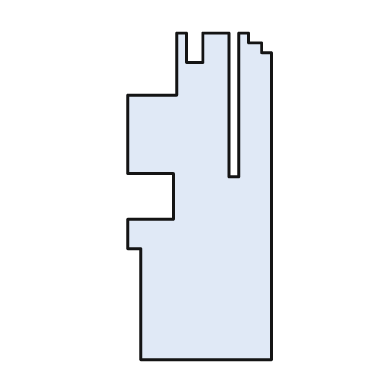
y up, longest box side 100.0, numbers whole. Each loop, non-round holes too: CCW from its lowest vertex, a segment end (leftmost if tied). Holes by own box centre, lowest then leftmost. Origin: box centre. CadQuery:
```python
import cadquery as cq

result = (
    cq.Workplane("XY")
    .moveTo(-18.0, -50.0)
    .lineTo(22.0, -50.0)
    .lineTo(22.0, 44.0)
    .lineTo(19.0, 44.0)
    .lineTo(19.0, 47.0)
    .lineTo(15.0, 47.0)
    .lineTo(15.0, 50.0)
    .lineTo(12.0, 50.0)
    .lineTo(12.0, 6.0)
    .lineTo(9.0, 6.0)
    .lineTo(9.0, 50.0)
    .lineTo(1.0, 50.0)
    .lineTo(1.0, 41.0)
    .lineTo(-4.0, 41.0)
    .lineTo(-4.0, 50.0)
    .lineTo(-7.0, 50.0)
    .lineTo(-7.0, 31.0)
    .lineTo(-22.0, 31.0)
    .lineTo(-22.0, 7.0)
    .lineTo(-8.0, 7.0)
    .lineTo(-8.0, -7.0)
    .lineTo(-22.0, -7.0)
    .lineTo(-22.0, -16.0)
    .lineTo(-18.0, -16.0)
    .close()
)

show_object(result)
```